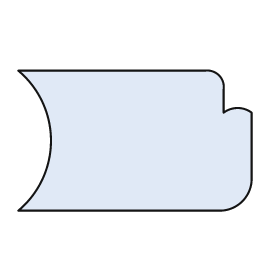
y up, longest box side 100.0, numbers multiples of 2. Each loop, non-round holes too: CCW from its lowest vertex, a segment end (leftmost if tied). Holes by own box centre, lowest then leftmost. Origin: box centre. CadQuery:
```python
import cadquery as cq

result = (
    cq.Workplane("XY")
    .moveTo(-50.0, -30.0)
    .lineTo(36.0, -30.0)
    .threePointArc((46.0, -26.0), (50.0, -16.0))
    .lineTo(50.0, 12.0)
    .threePointArc((44.0, 14.0), (38.0, 12.0))
    .lineTo(38.0, 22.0)
    .threePointArc((36.0, 28.0), (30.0, 30.0))
    .lineTo(-50.0, 30.0)
    .threePointArc((-36.0, 0.0), (-50.0, -30.0))
    .close()
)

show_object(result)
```